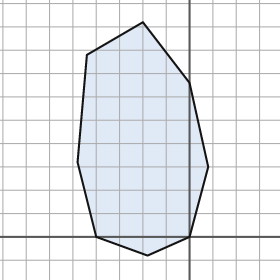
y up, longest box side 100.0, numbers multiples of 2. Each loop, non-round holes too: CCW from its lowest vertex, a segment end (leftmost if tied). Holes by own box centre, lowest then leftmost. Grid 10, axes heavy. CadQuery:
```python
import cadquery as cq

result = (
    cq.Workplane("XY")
    .moveTo(-18.0, -8.0)
    .lineTo(0.0, 0.0)
    .lineTo(8.0, 30.0)
    .lineTo(0.0, 66.0)
    .lineTo(-20.0, 92.0)
    .lineTo(-44.0, 78.0)
    .lineTo(-48.0, 32.0)
    .lineTo(-40.0, 0.0)
    .close()
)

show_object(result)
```